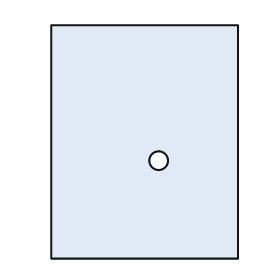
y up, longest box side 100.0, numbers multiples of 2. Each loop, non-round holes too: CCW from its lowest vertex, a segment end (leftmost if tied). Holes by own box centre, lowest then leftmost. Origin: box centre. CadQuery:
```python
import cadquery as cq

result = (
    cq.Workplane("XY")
    .moveTo(-40.0, -50.0)
    .lineTo(40.0, -50.0)
    .lineTo(40.0, 50.0)
    .lineTo(-40.0, 50.0)
    .close()
    .moveTo(6.0, -8.0)
    .circle(4.0)
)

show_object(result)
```